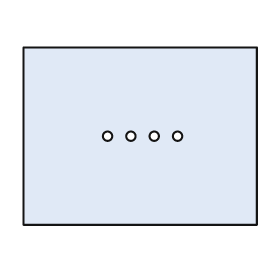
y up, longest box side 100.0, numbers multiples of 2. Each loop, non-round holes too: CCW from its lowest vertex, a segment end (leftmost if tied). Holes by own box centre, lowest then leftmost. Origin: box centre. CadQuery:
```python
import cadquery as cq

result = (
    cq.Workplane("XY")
    .moveTo(-50.0, -38.0)
    .lineTo(50.0, -38.0)
    .lineTo(50.0, 38.0)
    .lineTo(-50.0, 38.0)
    .close()
    .moveTo(-14.0, 0.0)
    .circle(2.0)
    .moveTo(-4.0, 0.0)
    .circle(2.0)
    .moveTo(6.0, 0.0)
    .circle(2.0)
    .moveTo(16.0, 0.0)
    .circle(2.0)
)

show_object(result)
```